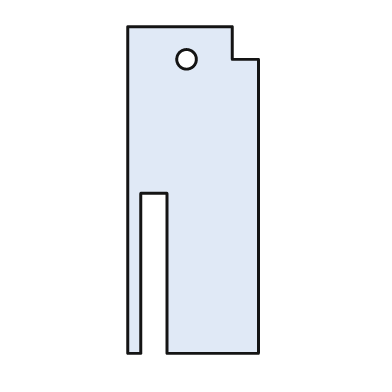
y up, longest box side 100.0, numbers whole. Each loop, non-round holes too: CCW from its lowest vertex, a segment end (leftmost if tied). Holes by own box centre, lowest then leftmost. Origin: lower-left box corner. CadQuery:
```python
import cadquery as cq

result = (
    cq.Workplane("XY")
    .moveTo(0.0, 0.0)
    .lineTo(4.0, 0.0)
    .lineTo(4.0, 49.0)
    .lineTo(12.0, 49.0)
    .lineTo(12.0, 0.0)
    .lineTo(40.0, 0.0)
    .lineTo(40.0, 90.0)
    .lineTo(32.0, 90.0)
    .lineTo(32.0, 100.0)
    .lineTo(0.0, 100.0)
    .close()
    .moveTo(18.0, 90.0)
    .circle(3.0)
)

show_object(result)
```